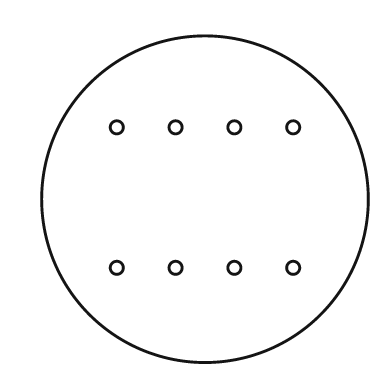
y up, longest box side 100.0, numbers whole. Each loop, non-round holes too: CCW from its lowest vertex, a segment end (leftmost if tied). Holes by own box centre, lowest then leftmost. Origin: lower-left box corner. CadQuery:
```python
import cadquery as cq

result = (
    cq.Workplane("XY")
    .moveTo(50.0, 50.0)
    .circle(50.0)
    .moveTo(23.0, 29.0)
    .circle(2.0)
    .moveTo(41.0, 29.0)
    .circle(2.0)
    .moveTo(59.0, 29.0)
    .circle(2.0)
    .moveTo(77.0, 29.0)
    .circle(2.0)
    .moveTo(23.0, 72.0)
    .circle(2.0)
    .moveTo(41.0, 72.0)
    .circle(2.0)
    .moveTo(59.0, 72.0)
    .circle(2.0)
    .moveTo(77.0, 72.0)
    .circle(2.0)
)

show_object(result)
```